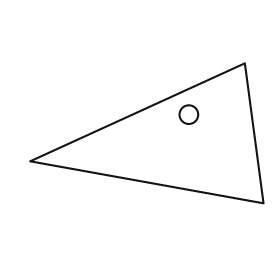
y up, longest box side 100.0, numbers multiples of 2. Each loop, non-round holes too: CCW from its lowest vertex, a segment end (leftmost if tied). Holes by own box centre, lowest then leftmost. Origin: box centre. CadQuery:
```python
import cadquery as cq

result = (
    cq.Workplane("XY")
    .moveTo(50.0, -30.0)
    .lineTo(42.0, 30.0)
    .lineTo(-50.0, -12.0)
    .close()
    .moveTo(18.0, 8.0)
    .circle(4.0)
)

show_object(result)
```